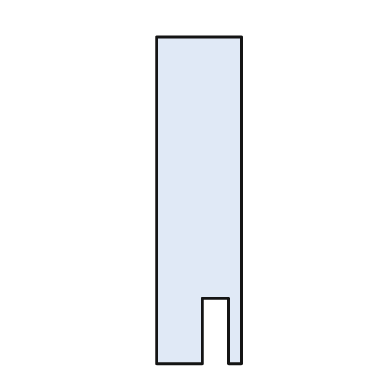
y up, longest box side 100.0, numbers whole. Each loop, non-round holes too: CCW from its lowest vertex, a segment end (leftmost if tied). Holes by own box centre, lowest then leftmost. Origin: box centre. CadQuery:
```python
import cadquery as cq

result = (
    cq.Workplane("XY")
    .moveTo(-13.0, -50.0)
    .lineTo(1.0, -50.0)
    .lineTo(1.0, -30.0)
    .lineTo(9.0, -30.0)
    .lineTo(9.0, -50.0)
    .lineTo(13.0, -50.0)
    .lineTo(13.0, 50.0)
    .lineTo(-13.0, 50.0)
    .close()
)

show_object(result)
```